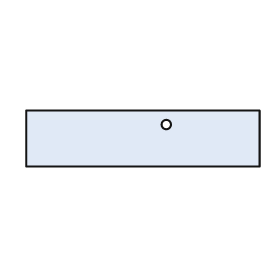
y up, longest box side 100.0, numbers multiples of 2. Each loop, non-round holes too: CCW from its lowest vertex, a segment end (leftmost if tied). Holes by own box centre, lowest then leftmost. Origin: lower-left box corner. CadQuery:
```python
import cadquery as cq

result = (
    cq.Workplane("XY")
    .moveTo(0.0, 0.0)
    .lineTo(100.0, 0.0)
    .lineTo(100.0, 24.0)
    .lineTo(0.0, 24.0)
    .close()
    .moveTo(60.0, 18.0)
    .circle(2.0)
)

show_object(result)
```